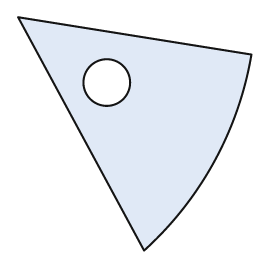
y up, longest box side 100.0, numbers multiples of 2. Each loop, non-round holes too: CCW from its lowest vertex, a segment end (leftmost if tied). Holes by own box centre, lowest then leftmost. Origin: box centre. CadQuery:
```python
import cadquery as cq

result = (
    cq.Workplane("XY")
    .moveTo(4.0, -50.0)
    .threePointArc((34.0, -12.0), (50.0, 34.0))
    .lineTo(-50.0, 50.0)
    .close()
    .moveTo(-12.0, 22.0)
    .circle(10.0)
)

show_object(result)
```